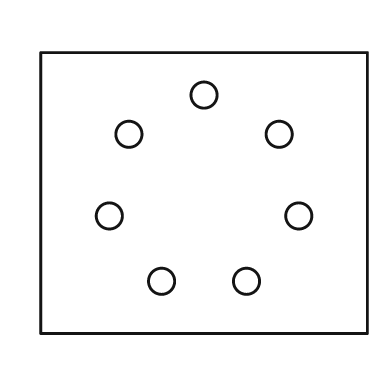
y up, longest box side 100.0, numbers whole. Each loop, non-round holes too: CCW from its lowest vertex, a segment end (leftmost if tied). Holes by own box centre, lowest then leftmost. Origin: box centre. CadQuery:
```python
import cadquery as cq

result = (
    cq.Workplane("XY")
    .moveTo(-50.0, -43.0)
    .lineTo(50.0, -43.0)
    .lineTo(50.0, 43.0)
    .lineTo(-50.0, 43.0)
    .close()
    .moveTo(-13.0, -27.0)
    .circle(4.0)
    .moveTo(13.0, -27.0)
    .circle(4.0)
    .moveTo(-29.0, -7.0)
    .circle(4.0)
    .moveTo(29.0, -7.0)
    .circle(4.0)
    .moveTo(-23.0, 18.0)
    .circle(4.0)
    .moveTo(23.0, 18.0)
    .circle(4.0)
    .moveTo(0.0, 30.0)
    .circle(4.0)
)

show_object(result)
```